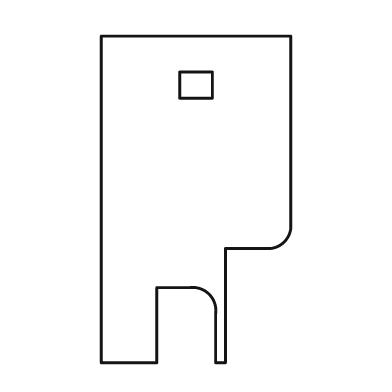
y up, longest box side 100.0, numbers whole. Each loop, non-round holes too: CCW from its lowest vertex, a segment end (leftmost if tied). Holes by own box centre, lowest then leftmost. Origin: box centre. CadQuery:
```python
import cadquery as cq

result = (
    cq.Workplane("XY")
    .moveTo(-29.0, -50.0)
    .lineTo(-12.0, -50.0)
    .lineTo(-12.0, -27.0)
    .lineTo(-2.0, -27.0)
    .threePointArc((4.0, -29.0), (6.0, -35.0))
    .lineTo(6.0, -50.0)
    .lineTo(9.0, -50.0)
    .lineTo(9.0, -15.0)
    .lineTo(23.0, -15.0)
    .threePointArc((27.0, -13.0), (29.0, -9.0))
    .lineTo(29.0, 50.0)
    .lineTo(-29.0, 50.0)
    .close()
    .moveTo(-5.0, 31.0)
    .lineTo(5.0, 31.0)
    .lineTo(5.0, 39.0)
    .lineTo(-5.0, 39.0)
    .close()
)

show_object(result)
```